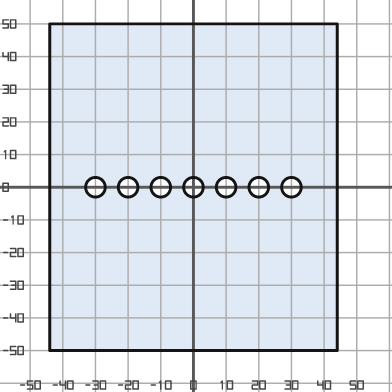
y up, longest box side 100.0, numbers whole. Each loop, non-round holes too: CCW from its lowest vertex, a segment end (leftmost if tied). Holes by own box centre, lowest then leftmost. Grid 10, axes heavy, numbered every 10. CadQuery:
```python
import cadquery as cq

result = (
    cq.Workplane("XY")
    .moveTo(-44.0, -50.0)
    .lineTo(44.0, -50.0)
    .lineTo(44.0, 50.0)
    .lineTo(-44.0, 50.0)
    .close()
    .moveTo(-30.0, 0.0)
    .circle(3.0)
    .moveTo(-20.0, 0.0)
    .circle(3.0)
    .moveTo(-10.0, 0.0)
    .circle(3.0)
    .moveTo(0.0, 0.0)
    .circle(3.0)
    .moveTo(10.0, 0.0)
    .circle(3.0)
    .moveTo(20.0, 0.0)
    .circle(3.0)
    .moveTo(30.0, 0.0)
    .circle(3.0)
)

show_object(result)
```